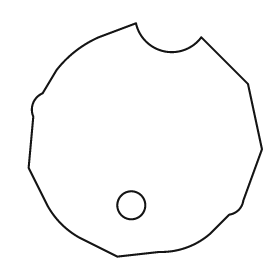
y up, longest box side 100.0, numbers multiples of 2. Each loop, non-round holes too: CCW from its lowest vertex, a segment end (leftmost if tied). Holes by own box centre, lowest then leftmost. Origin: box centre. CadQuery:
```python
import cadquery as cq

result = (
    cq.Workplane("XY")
    .moveTo(-12.0, -50.0)
    .lineTo(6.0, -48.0)
    .threePointArc((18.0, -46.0), (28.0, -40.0))
    .lineTo(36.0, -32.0)
    .threePointArc((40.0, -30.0), (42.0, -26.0))
    .lineTo(50.0, -4.0)
    .lineTo(44.0, 24.0)
    .lineTo(24.0, 44.0)
    .threePointArc((8.0, 38.0), (-4.0, 50.0))
    .lineTo(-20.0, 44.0)
    .threePointArc((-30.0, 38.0), (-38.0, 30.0))
    .lineTo(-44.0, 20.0)
    .threePointArc((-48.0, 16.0), (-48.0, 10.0))
    .lineTo(-50.0, -12.0)
    .lineTo(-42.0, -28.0)
    .threePointArc((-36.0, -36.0), (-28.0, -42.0))
    .close()
    .moveTo(-6.0, -28.0)
    .circle(6.0)
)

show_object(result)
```